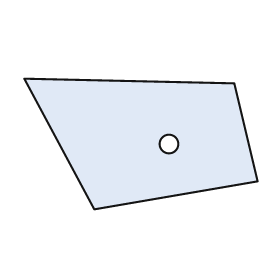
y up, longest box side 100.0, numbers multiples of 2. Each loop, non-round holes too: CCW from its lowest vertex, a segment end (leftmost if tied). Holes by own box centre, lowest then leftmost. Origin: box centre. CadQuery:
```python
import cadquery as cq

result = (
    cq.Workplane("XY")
    .moveTo(-20.0, -28.0)
    .lineTo(50.0, -16.0)
    .lineTo(40.0, 26.0)
    .lineTo(-50.0, 28.0)
    .close()
    .moveTo(12.0, 0.0)
    .circle(4.0)
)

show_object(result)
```